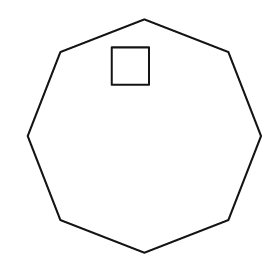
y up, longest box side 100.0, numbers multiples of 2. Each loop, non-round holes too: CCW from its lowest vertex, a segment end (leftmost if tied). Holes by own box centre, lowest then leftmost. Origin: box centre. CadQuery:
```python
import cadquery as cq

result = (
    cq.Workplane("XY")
    .moveTo(0.0, -50.0)
    .lineTo(36.0, -36.0)
    .lineTo(50.0, 0.0)
    .lineTo(36.0, 36.0)
    .lineTo(0.0, 50.0)
    .lineTo(-36.0, 36.0)
    .lineTo(-50.0, 0.0)
    .lineTo(-36.0, -36.0)
    .close()
    .moveTo(-14.0, 22.0)
    .lineTo(2.0, 22.0)
    .lineTo(2.0, 38.0)
    .lineTo(-14.0, 38.0)
    .close()
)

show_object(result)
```